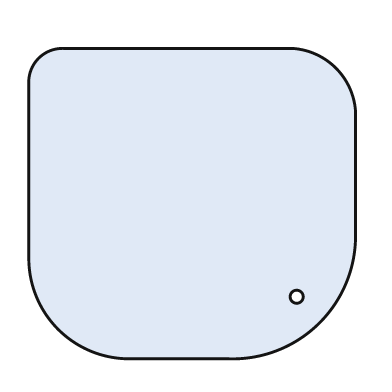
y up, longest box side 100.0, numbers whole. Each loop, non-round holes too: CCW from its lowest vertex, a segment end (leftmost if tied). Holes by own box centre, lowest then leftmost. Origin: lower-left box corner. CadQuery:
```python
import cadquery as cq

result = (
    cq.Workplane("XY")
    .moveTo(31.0, 0.0)
    .lineTo(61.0, 0.0)
    .threePointArc((89.0, 11.0), (100.0, 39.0))
    .lineTo(100.0, 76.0)
    .threePointArc((94.0, 89.0), (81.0, 95.0))
    .lineTo(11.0, 95.0)
    .threePointArc((3.0, 92.0), (0.0, 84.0))
    .lineTo(0.0, 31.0)
    .threePointArc((9.0, 9.0), (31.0, 0.0))
    .close()
    .moveTo(82.0, 19.0)
    .circle(2.0)
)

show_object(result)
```